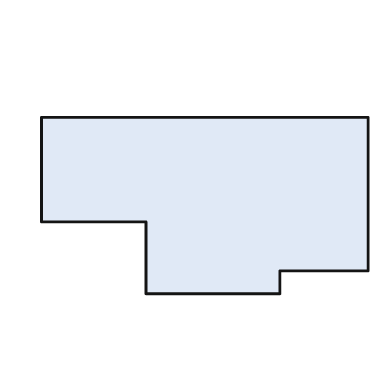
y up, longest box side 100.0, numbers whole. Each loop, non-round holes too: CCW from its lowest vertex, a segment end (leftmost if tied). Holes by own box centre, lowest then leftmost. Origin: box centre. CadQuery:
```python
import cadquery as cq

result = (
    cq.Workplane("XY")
    .moveTo(-18.0, -27.0)
    .lineTo(23.0, -27.0)
    .lineTo(23.0, -20.0)
    .lineTo(50.0, -20.0)
    .lineTo(50.0, 27.0)
    .lineTo(-50.0, 27.0)
    .lineTo(-50.0, -5.0)
    .lineTo(-18.0, -5.0)
    .close()
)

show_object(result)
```